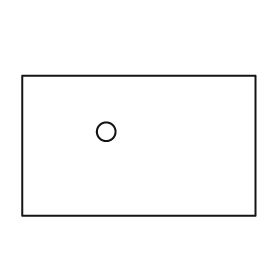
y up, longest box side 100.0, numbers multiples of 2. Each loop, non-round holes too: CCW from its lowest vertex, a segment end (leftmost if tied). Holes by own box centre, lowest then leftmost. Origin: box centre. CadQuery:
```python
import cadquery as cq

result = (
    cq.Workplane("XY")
    .moveTo(-50.0, -30.0)
    .lineTo(50.0, -30.0)
    .lineTo(50.0, 30.0)
    .lineTo(-50.0, 30.0)
    .close()
    .moveTo(-14.0, 6.0)
    .circle(4.0)
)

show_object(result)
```